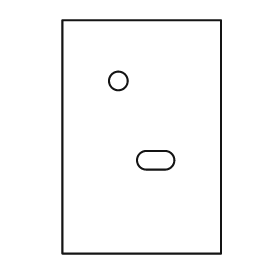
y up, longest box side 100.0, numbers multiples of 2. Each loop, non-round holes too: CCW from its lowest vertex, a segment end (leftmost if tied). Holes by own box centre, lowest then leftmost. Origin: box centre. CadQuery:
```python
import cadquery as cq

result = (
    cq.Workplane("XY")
    .moveTo(-34.0, -50.0)
    .lineTo(34.0, -50.0)
    .lineTo(34.0, 50.0)
    .lineTo(-34.0, 50.0)
    .close()
    .moveTo(2.0, -14.0)
    .lineTo(10.0, -14.0)
    .threePointArc((14.0, -10.0), (10.0, -6.0))
    .lineTo(2.0, -6.0)
    .threePointArc((-2.0, -10.0), (2.0, -14.0))
    .close()
    .moveTo(-10.0, 24.0)
    .circle(4.0)
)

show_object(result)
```